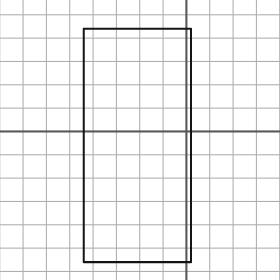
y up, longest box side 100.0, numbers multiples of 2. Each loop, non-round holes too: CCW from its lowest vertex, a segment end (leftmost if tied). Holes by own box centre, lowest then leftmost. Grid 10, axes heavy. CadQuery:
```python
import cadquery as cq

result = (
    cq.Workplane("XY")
    .moveTo(-44.0, -56.0)
    .lineTo(2.0, -56.0)
    .lineTo(2.0, 44.0)
    .lineTo(-44.0, 44.0)
    .close()
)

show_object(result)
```